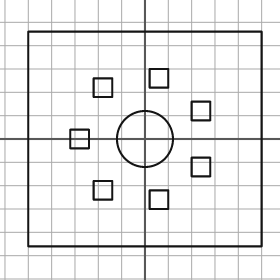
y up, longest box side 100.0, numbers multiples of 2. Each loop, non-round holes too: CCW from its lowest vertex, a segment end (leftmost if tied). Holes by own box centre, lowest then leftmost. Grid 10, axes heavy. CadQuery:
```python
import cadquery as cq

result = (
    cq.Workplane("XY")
    .moveTo(-50.0, -46.0)
    .lineTo(50.0, -46.0)
    .lineTo(50.0, 46.0)
    .lineTo(-50.0, 46.0)
    .close()
    .moveTo(2.0, -30.0)
    .lineTo(10.0, -30.0)
    .lineTo(10.0, -22.0)
    .lineTo(2.0, -22.0)
    .close()
    .moveTo(-22.0, -26.0)
    .lineTo(-14.0, -26.0)
    .lineTo(-14.0, -18.0)
    .lineTo(-22.0, -18.0)
    .close()
    .moveTo(20.0, -16.0)
    .lineTo(28.0, -16.0)
    .lineTo(28.0, -8.0)
    .lineTo(20.0, -8.0)
    .close()
    .moveTo(-32.0, -4.0)
    .lineTo(-24.0, -4.0)
    .lineTo(-24.0, 4.0)
    .lineTo(-32.0, 4.0)
    .close()
    .moveTo(0.0, 0.0)
    .circle(12.0)
    .moveTo(20.0, 8.0)
    .lineTo(28.0, 8.0)
    .lineTo(28.0, 16.0)
    .lineTo(20.0, 16.0)
    .close()
    .moveTo(-22.0, 18.0)
    .lineTo(-14.0, 18.0)
    .lineTo(-14.0, 26.0)
    .lineTo(-22.0, 26.0)
    .close()
    .moveTo(2.0, 22.0)
    .lineTo(10.0, 22.0)
    .lineTo(10.0, 30.0)
    .lineTo(2.0, 30.0)
    .close()
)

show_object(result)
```